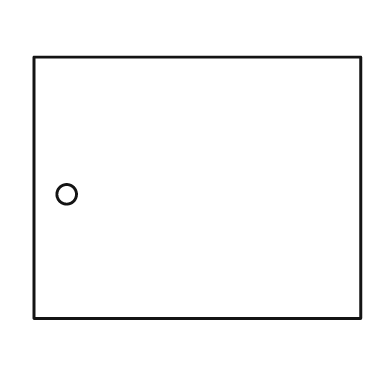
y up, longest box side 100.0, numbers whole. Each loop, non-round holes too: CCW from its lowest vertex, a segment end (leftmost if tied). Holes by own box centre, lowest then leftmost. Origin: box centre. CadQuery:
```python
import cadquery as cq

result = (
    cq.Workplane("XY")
    .moveTo(-50.0, -40.0)
    .lineTo(50.0, -40.0)
    .lineTo(50.0, 40.0)
    .lineTo(-50.0, 40.0)
    .close()
    .moveTo(-40.0, -2.0)
    .circle(3.0)
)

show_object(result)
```